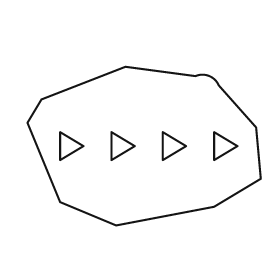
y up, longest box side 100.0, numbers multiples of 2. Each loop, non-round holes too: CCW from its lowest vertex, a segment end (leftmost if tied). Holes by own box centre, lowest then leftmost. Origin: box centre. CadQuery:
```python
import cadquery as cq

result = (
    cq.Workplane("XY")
    .moveTo(-12.0, -34.0)
    .lineTo(30.0, -26.0)
    .lineTo(50.0, -14.0)
    .lineTo(48.0, 8.0)
    .lineTo(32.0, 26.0)
    .threePointArc((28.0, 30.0), (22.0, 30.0))
    .lineTo(-8.0, 34.0)
    .lineTo(-44.0, 20.0)
    .lineTo(-50.0, 10.0)
    .lineTo(-36.0, -24.0)
    .close()
    .moveTo(-36.0, -6.0)
    .lineTo(-26.0, 0.0)
    .lineTo(-36.0, 6.0)
    .close()
    .moveTo(-14.0, -6.0)
    .lineTo(-4.0, 0.0)
    .lineTo(-14.0, 6.0)
    .close()
    .moveTo(8.0, -6.0)
    .lineTo(18.0, 0.0)
    .lineTo(8.0, 6.0)
    .close()
    .moveTo(30.0, -6.0)
    .lineTo(40.0, 0.0)
    .lineTo(30.0, 6.0)
    .close()
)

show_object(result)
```